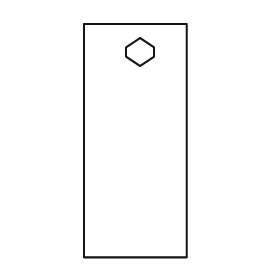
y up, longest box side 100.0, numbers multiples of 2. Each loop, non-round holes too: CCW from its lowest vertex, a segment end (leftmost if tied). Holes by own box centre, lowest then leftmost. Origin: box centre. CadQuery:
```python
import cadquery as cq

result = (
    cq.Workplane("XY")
    .moveTo(-22.0, -50.0)
    .lineTo(22.0, -50.0)
    .lineTo(22.0, 50.0)
    .lineTo(-22.0, 50.0)
    .close()
    .moveTo(2.0, 32.0)
    .lineTo(8.0, 36.0)
    .lineTo(8.0, 40.0)
    .lineTo(2.0, 44.0)
    .lineTo(-4.0, 40.0)
    .lineTo(-4.0, 36.0)
    .close()
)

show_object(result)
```